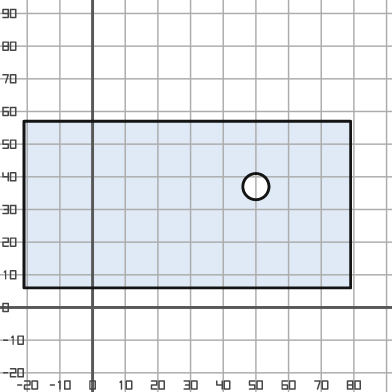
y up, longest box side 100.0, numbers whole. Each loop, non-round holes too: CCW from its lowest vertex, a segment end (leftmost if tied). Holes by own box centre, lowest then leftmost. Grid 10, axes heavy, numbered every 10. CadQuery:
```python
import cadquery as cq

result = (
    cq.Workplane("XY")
    .moveTo(-21.0, 6.0)
    .lineTo(79.0, 6.0)
    .lineTo(79.0, 57.0)
    .lineTo(-21.0, 57.0)
    .close()
    .moveTo(50.0, 37.0)
    .circle(4.0)
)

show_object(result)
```